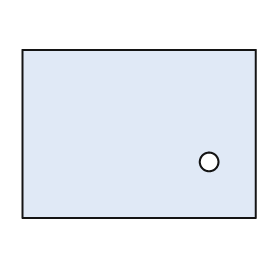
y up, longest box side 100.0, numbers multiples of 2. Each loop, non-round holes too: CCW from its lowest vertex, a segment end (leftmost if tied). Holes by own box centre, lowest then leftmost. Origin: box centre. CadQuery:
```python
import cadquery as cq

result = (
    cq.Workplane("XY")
    .moveTo(-50.0, -36.0)
    .lineTo(50.0, -36.0)
    .lineTo(50.0, 36.0)
    .lineTo(-50.0, 36.0)
    .close()
    .moveTo(30.0, -12.0)
    .circle(4.0)
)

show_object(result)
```